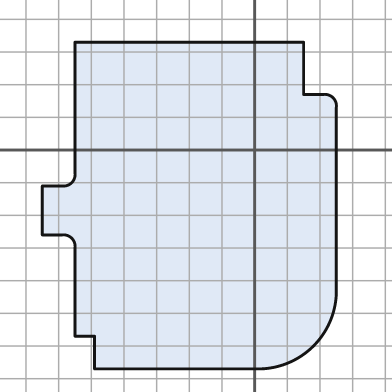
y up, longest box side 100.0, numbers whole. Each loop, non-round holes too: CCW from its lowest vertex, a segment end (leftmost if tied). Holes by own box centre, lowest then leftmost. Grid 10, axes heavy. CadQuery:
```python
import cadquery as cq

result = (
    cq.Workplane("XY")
    .moveTo(-49.0, -67.0)
    .lineTo(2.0, -67.0)
    .threePointArc((18.0, -60.0), (25.0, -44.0))
    .lineTo(25.0, 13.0)
    .threePointArc((24.0, 16.0), (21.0, 17.0))
    .lineTo(15.0, 17.0)
    .lineTo(15.0, 33.0)
    .lineTo(-55.0, 33.0)
    .lineTo(-55.0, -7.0)
    .threePointArc((-56.0, -10.0), (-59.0, -11.0))
    .lineTo(-65.0, -11.0)
    .lineTo(-65.0, -26.0)
    .lineTo(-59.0, -26.0)
    .threePointArc((-56.0, -27.0), (-55.0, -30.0))
    .lineTo(-55.0, -57.0)
    .lineTo(-49.0, -57.0)
    .close()
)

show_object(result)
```